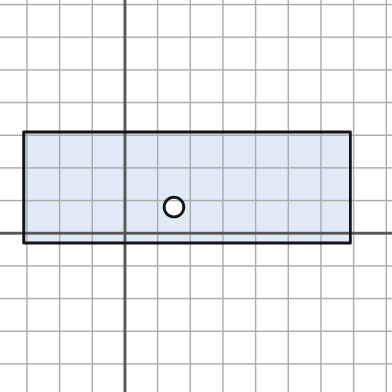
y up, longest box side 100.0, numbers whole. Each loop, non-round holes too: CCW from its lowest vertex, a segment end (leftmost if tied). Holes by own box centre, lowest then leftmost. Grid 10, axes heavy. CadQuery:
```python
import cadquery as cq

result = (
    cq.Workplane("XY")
    .moveTo(-31.0, -3.0)
    .lineTo(69.0, -3.0)
    .lineTo(69.0, 31.0)
    .lineTo(-31.0, 31.0)
    .close()
    .moveTo(15.0, 8.0)
    .circle(3.0)
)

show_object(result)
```